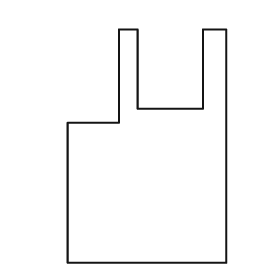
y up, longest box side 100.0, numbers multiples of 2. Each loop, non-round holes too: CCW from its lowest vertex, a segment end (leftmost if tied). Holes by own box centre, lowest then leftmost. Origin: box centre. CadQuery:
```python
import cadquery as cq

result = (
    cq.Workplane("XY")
    .moveTo(-34.0, -50.0)
    .lineTo(34.0, -50.0)
    .lineTo(34.0, 50.0)
    .lineTo(24.0, 50.0)
    .lineTo(24.0, 16.0)
    .lineTo(-4.0, 16.0)
    .lineTo(-4.0, 50.0)
    .lineTo(-12.0, 50.0)
    .lineTo(-12.0, 10.0)
    .lineTo(-34.0, 10.0)
    .close()
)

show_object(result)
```